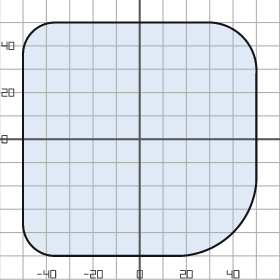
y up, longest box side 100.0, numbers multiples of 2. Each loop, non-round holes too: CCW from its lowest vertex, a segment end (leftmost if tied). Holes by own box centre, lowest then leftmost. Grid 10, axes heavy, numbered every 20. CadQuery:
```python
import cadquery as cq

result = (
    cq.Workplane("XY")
    .moveTo(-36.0, -50.0)
    .lineTo(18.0, -50.0)
    .threePointArc((40.0, -40.0), (50.0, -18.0))
    .lineTo(50.0, 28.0)
    .threePointArc((44.0, 44.0), (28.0, 50.0))
    .lineTo(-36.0, 50.0)
    .threePointArc((-46.0, 46.0), (-50.0, 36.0))
    .lineTo(-50.0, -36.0)
    .threePointArc((-46.0, -46.0), (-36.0, -50.0))
    .close()
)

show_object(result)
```